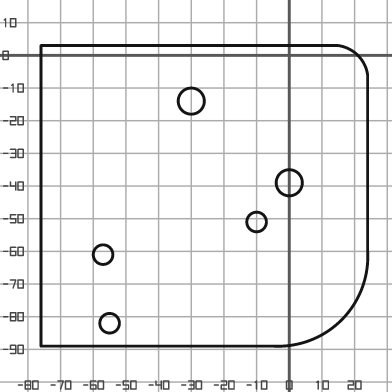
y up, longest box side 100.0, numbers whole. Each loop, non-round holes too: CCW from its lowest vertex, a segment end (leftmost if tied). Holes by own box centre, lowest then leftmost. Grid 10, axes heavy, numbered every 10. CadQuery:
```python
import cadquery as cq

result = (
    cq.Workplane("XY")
    .moveTo(-76.0, -89.0)
    .lineTo(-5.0, -89.0)
    .threePointArc((16.0, -81.0), (24.0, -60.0))
    .lineTo(24.0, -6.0)
    .threePointArc((21.0, 0.0), (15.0, 3.0))
    .lineTo(-76.0, 3.0)
    .close()
    .moveTo(-55.0, -82.0)
    .circle(3.0)
    .moveTo(-57.0, -61.0)
    .circle(3.0)
    .moveTo(-10.0, -51.0)
    .circle(3.0)
    .moveTo(0.0, -39.0)
    .circle(4.0)
    .moveTo(-30.0, -14.0)
    .circle(4.0)
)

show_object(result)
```